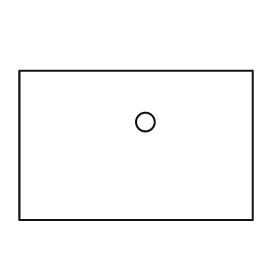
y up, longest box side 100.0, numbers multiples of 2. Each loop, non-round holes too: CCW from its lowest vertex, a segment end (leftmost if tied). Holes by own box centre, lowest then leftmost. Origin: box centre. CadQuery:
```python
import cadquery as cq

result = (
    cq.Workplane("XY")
    .moveTo(-50.0, -32.0)
    .lineTo(50.0, -32.0)
    .lineTo(50.0, 32.0)
    .lineTo(-50.0, 32.0)
    .close()
    .moveTo(4.0, 10.0)
    .circle(4.0)
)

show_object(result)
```